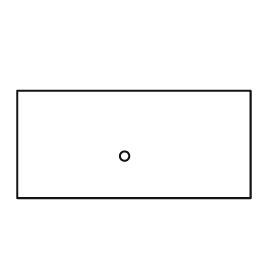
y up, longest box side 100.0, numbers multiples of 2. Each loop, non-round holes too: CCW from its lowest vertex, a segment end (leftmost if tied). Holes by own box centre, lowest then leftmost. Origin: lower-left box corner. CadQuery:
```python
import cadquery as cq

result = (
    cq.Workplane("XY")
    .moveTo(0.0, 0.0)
    .lineTo(100.0, 0.0)
    .lineTo(100.0, 46.0)
    .lineTo(0.0, 46.0)
    .close()
    .moveTo(46.0, 18.0)
    .circle(2.0)
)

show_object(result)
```